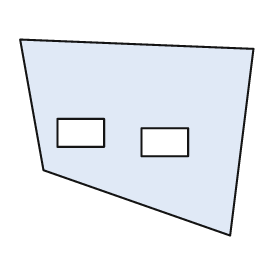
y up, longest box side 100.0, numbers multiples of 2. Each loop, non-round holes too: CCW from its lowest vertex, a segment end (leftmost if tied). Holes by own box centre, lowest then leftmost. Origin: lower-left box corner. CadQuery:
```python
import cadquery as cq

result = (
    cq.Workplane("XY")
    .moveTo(90.0, 0.0)
    .lineTo(100.0, 80.0)
    .lineTo(0.0, 84.0)
    .lineTo(10.0, 28.0)
    .close()
    .moveTo(52.0, 34.0)
    .lineTo(72.0, 34.0)
    .lineTo(72.0, 46.0)
    .lineTo(52.0, 46.0)
    .close()
    .moveTo(16.0, 38.0)
    .lineTo(36.0, 38.0)
    .lineTo(36.0, 50.0)
    .lineTo(16.0, 50.0)
    .close()
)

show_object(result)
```